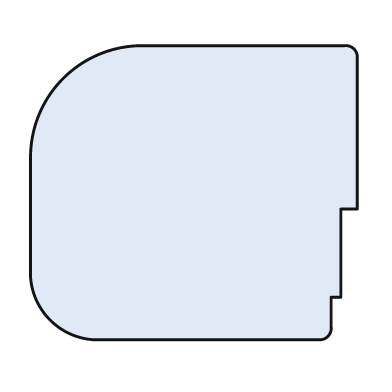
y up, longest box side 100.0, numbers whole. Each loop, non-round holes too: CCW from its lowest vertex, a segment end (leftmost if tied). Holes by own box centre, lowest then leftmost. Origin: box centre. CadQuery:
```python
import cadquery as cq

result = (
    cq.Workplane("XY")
    .moveTo(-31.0, -45.0)
    .lineTo(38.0, -45.0)
    .threePointArc((41.0, -44.0), (42.0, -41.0))
    .lineTo(42.0, -32.0)
    .lineTo(45.0, -32.0)
    .lineTo(45.0, -5.0)
    .lineTo(50.0, -5.0)
    .lineTo(50.0, 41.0)
    .threePointArc((49.0, 44.0), (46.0, 45.0))
    .lineTo(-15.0, 45.0)
    .threePointArc((-40.0, 35.0), (-50.0, 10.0))
    .lineTo(-50.0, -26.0)
    .threePointArc((-44.0, -39.0), (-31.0, -45.0))
    .close()
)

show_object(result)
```